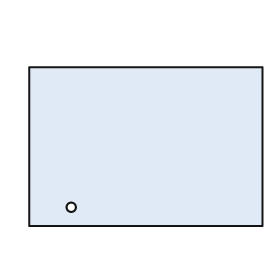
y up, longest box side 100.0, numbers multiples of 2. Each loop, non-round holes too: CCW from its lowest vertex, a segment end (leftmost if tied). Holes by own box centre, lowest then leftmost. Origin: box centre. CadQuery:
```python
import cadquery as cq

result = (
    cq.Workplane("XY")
    .moveTo(-50.0, -34.0)
    .lineTo(50.0, -34.0)
    .lineTo(50.0, 34.0)
    .lineTo(-50.0, 34.0)
    .close()
    .moveTo(-32.0, -26.0)
    .circle(2.0)
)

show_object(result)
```